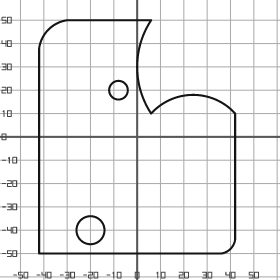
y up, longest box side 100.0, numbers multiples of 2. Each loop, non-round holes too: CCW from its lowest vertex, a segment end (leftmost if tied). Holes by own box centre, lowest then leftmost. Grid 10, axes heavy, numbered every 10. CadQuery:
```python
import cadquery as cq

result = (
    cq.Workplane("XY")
    .moveTo(-42.0, -50.0)
    .lineTo(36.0, -50.0)
    .threePointArc((40.0, -48.0), (42.0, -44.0))
    .lineTo(42.0, 10.0)
    .threePointArc((24.0, 18.0), (6.0, 10.0))
    .threePointArc((0.0, 30.0), (6.0, 50.0))
    .lineTo(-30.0, 50.0)
    .threePointArc((-38.0, 46.0), (-42.0, 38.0))
    .close()
    .moveTo(-20.0, -40.0)
    .circle(6.0)
    .moveTo(-8.0, 20.0)
    .circle(4.0)
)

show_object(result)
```